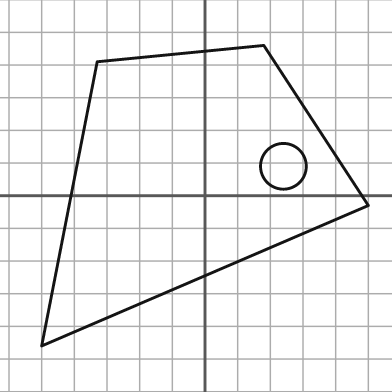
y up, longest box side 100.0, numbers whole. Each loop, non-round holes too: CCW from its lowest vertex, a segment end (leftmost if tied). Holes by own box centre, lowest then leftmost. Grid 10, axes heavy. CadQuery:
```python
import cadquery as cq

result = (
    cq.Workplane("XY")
    .moveTo(-50.0, -46.0)
    .lineTo(50.0, -3.0)
    .lineTo(18.0, 46.0)
    .lineTo(-33.0, 41.0)
    .close()
    .moveTo(24.0, 9.0)
    .circle(7.0)
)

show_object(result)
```